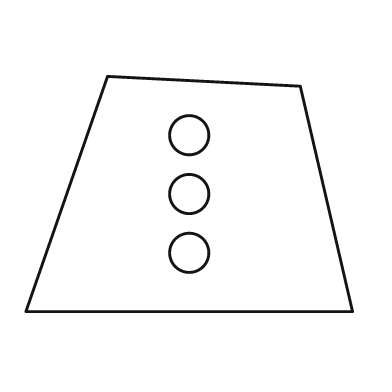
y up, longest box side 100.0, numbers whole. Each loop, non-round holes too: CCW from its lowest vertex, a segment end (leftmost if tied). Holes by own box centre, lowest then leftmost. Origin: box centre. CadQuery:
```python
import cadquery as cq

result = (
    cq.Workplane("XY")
    .moveTo(-50.0, -36.0)
    .lineTo(50.0, -36.0)
    .lineTo(34.0, 33.0)
    .lineTo(-25.0, 36.0)
    .close()
    .moveTo(0.0, -18.0)
    .circle(6.0)
    .moveTo(0.0, 0.0)
    .circle(6.0)
    .moveTo(0.0, 18.0)
    .circle(6.0)
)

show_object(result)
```